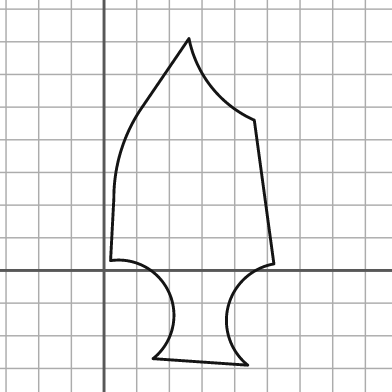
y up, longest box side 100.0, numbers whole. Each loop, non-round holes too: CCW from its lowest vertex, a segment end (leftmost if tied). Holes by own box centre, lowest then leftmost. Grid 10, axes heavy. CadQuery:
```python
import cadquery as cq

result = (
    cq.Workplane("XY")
    .moveTo(44.0, -29.0)
    .threePointArc((38.0, -11.0), (52.0, 2.0))
    .lineTo(46.0, 46.0)
    .threePointArc((33.0, 56.0), (26.0, 71.0))
    .lineTo(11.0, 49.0)
    .threePointArc((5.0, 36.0), (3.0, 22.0))
    .lineTo(2.0, 3.0)
    .threePointArc((20.0, -7.0), (15.0, -27.0))
    .close()
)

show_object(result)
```